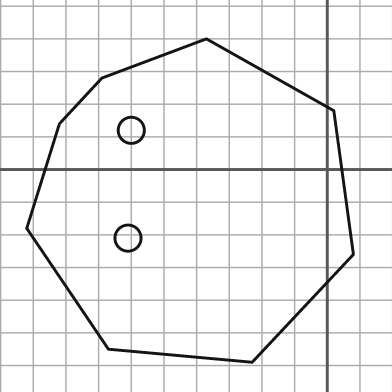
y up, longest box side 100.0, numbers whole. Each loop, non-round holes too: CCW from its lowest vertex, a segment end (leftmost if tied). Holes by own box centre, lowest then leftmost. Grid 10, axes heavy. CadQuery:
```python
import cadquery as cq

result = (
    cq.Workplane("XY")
    .moveTo(-23.0, -59.0)
    .lineTo(8.0, -26.0)
    .lineTo(2.0, 18.0)
    .lineTo(-37.0, 40.0)
    .lineTo(-69.0, 28.0)
    .lineTo(-82.0, 14.0)
    .lineTo(-92.0, -18.0)
    .lineTo(-67.0, -55.0)
    .close()
    .moveTo(-61.0, -21.0)
    .circle(4.0)
    .moveTo(-60.0, 12.0)
    .circle(4.0)
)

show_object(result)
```